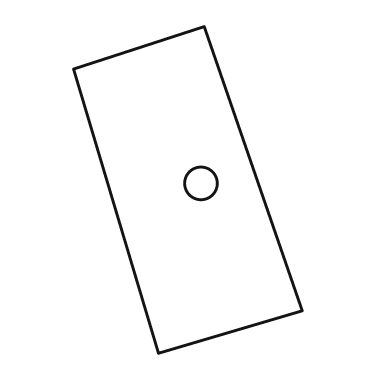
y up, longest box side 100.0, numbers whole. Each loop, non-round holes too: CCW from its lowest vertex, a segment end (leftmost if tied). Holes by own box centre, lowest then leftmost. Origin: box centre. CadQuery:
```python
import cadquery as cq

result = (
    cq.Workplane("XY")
    .moveTo(-9.0, -50.0)
    .lineTo(35.0, -37.0)
    .lineTo(5.0, 50.0)
    .lineTo(-35.0, 37.0)
    .close()
    .moveTo(4.0, 2.0)
    .circle(5.0)
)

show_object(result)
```